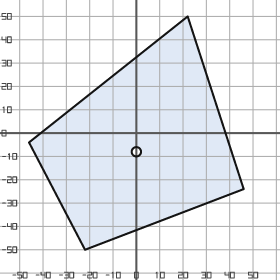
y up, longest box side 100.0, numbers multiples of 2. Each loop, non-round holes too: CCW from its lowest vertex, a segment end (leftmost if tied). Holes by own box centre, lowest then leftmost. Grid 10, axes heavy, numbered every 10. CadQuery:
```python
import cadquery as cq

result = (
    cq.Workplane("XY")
    .moveTo(-22.0, -50.0)
    .lineTo(46.0, -24.0)
    .lineTo(22.0, 50.0)
    .lineTo(-46.0, -4.0)
    .close()
    .moveTo(0.0, -8.0)
    .circle(2.0)
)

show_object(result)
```